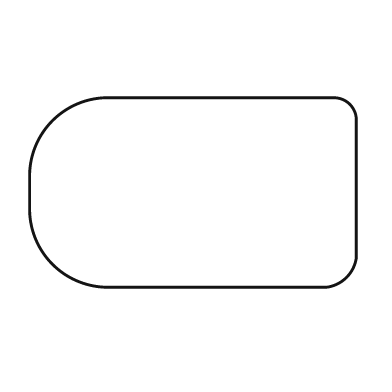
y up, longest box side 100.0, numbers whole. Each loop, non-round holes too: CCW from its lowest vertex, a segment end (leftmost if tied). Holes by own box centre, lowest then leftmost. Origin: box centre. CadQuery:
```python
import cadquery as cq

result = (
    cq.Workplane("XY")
    .moveTo(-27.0, -29.0)
    .lineTo(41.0, -29.0)
    .threePointArc((47.0, -26.0), (50.0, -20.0))
    .lineTo(50.0, 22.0)
    .threePointArc((48.0, 27.0), (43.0, 29.0))
    .lineTo(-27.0, 29.0)
    .threePointArc((-43.0, 22.0), (-50.0, 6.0))
    .lineTo(-50.0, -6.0)
    .threePointArc((-43.0, -22.0), (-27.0, -29.0))
    .close()
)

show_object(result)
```